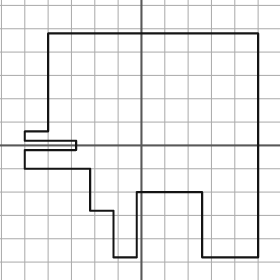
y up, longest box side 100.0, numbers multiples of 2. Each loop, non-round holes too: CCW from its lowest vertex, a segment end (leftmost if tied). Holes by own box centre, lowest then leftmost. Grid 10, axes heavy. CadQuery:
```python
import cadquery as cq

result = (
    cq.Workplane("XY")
    .moveTo(-12.0, -48.0)
    .lineTo(-2.0, -48.0)
    .lineTo(-2.0, -20.0)
    .lineTo(26.0, -20.0)
    .lineTo(26.0, -48.0)
    .lineTo(50.0, -48.0)
    .lineTo(50.0, 48.0)
    .lineTo(-40.0, 48.0)
    .lineTo(-40.0, 6.0)
    .lineTo(-50.0, 6.0)
    .lineTo(-50.0, 2.0)
    .lineTo(-28.0, 2.0)
    .lineTo(-28.0, -2.0)
    .lineTo(-50.0, -2.0)
    .lineTo(-50.0, -10.0)
    .lineTo(-22.0, -10.0)
    .lineTo(-22.0, -28.0)
    .lineTo(-12.0, -28.0)
    .close()
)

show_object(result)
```